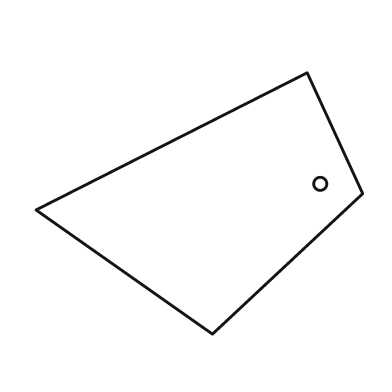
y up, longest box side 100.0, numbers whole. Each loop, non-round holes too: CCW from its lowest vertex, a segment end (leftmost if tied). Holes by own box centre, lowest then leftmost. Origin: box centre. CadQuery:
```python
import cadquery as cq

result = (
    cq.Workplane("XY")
    .moveTo(4.0, -40.0)
    .lineTo(50.0, 3.0)
    .lineTo(33.0, 40.0)
    .lineTo(-50.0, -2.0)
    .close()
    .moveTo(37.0, 6.0)
    .circle(2.0)
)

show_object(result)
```